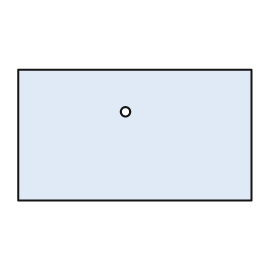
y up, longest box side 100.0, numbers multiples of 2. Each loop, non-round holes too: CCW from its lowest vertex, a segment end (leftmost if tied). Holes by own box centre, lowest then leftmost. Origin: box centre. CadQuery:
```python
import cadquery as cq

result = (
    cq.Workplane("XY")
    .moveTo(-50.0, -28.0)
    .lineTo(50.0, -28.0)
    .lineTo(50.0, 28.0)
    .lineTo(-50.0, 28.0)
    .close()
    .moveTo(-4.0, 10.0)
    .circle(2.0)
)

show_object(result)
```